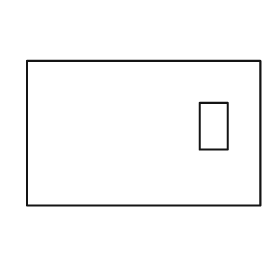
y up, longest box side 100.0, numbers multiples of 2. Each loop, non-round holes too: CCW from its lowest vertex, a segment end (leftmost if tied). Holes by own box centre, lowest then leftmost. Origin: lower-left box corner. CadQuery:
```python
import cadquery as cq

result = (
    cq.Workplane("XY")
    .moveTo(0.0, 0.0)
    .lineTo(100.0, 0.0)
    .lineTo(100.0, 62.0)
    .lineTo(0.0, 62.0)
    .close()
    .moveTo(74.0, 24.0)
    .lineTo(86.0, 24.0)
    .lineTo(86.0, 44.0)
    .lineTo(74.0, 44.0)
    .close()
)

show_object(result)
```